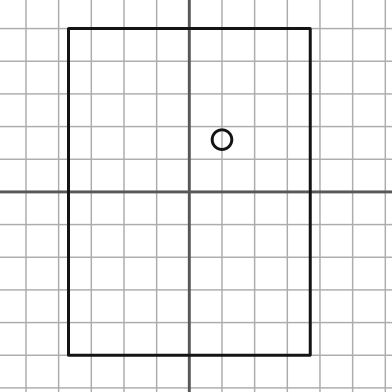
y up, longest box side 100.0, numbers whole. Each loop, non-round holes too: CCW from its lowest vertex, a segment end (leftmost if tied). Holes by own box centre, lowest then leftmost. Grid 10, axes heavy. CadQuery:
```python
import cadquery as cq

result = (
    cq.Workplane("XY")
    .moveTo(-37.0, -50.0)
    .lineTo(37.0, -50.0)
    .lineTo(37.0, 50.0)
    .lineTo(-37.0, 50.0)
    .close()
    .moveTo(10.0, 16.0)
    .circle(3.0)
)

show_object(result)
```